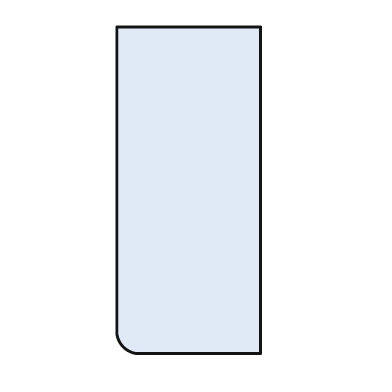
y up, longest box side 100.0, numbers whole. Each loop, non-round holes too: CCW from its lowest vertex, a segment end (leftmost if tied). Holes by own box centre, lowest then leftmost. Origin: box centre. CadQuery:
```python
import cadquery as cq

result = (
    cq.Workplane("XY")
    .moveTo(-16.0, -50.0)
    .lineTo(22.0, -50.0)
    .lineTo(22.0, 50.0)
    .lineTo(-22.0, 50.0)
    .lineTo(-22.0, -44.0)
    .threePointArc((-20.0, -48.0), (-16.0, -50.0))
    .close()
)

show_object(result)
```